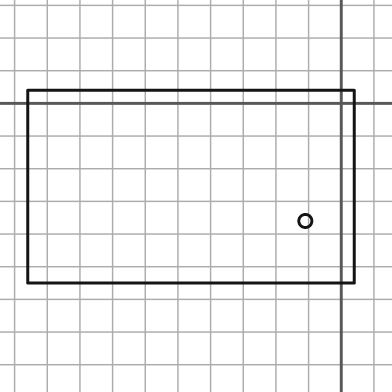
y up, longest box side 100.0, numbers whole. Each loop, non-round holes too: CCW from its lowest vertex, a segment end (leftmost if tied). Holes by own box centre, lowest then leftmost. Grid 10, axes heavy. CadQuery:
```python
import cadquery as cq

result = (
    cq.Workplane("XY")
    .moveTo(-96.0, -55.0)
    .lineTo(4.0, -55.0)
    .lineTo(4.0, 4.0)
    .lineTo(-96.0, 4.0)
    .close()
    .moveTo(-11.0, -36.0)
    .circle(2.0)
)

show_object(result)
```